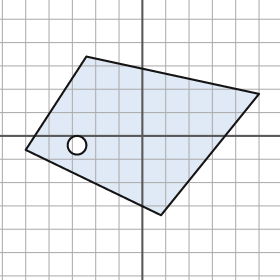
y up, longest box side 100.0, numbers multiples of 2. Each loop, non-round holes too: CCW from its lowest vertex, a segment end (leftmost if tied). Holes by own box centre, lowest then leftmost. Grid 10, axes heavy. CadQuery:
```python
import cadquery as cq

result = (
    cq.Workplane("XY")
    .moveTo(8.0, -34.0)
    .lineTo(50.0, 18.0)
    .lineTo(-24.0, 34.0)
    .lineTo(-50.0, -6.0)
    .close()
    .moveTo(-28.0, -4.0)
    .circle(4.0)
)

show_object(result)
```